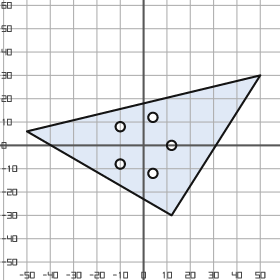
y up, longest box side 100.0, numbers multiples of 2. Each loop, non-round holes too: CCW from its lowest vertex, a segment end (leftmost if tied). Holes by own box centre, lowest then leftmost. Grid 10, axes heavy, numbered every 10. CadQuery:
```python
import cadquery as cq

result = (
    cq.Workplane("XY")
    .moveTo(12.0, -30.0)
    .lineTo(50.0, 30.0)
    .lineTo(-50.0, 6.0)
    .close()
    .moveTo(4.0, -12.0)
    .circle(2.0)
    .moveTo(-10.0, -8.0)
    .circle(2.0)
    .moveTo(12.0, 0.0)
    .circle(2.0)
    .moveTo(-10.0, 8.0)
    .circle(2.0)
    .moveTo(4.0, 12.0)
    .circle(2.0)
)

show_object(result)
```